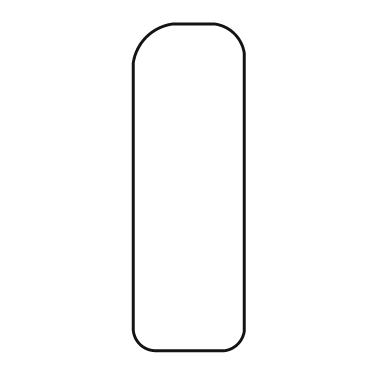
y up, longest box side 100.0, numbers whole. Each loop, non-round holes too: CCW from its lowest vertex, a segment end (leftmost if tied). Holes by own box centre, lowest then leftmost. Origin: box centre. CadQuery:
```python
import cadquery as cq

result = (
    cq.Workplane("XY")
    .moveTo(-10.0, -50.0)
    .lineTo(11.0, -50.0)
    .threePointArc((15.0, -48.0), (17.0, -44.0))
    .lineTo(17.0, 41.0)
    .threePointArc((14.0, 47.0), (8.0, 50.0))
    .lineTo(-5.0, 50.0)
    .threePointArc((-13.0, 46.0), (-17.0, 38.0))
    .lineTo(-17.0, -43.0)
    .threePointArc((-15.0, -48.0), (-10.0, -50.0))
    .close()
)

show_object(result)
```